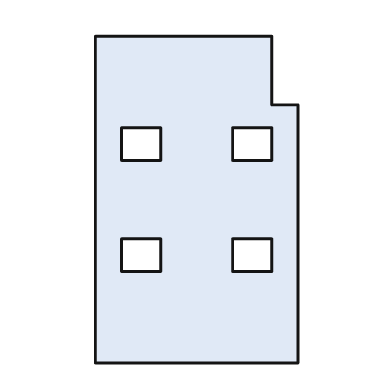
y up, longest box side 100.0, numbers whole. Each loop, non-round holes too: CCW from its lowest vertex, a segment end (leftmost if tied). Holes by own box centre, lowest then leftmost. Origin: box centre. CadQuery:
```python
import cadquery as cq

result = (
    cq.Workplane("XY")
    .moveTo(-31.0, -50.0)
    .lineTo(31.0, -50.0)
    .lineTo(31.0, 29.0)
    .lineTo(23.0, 29.0)
    .lineTo(23.0, 50.0)
    .lineTo(-31.0, 50.0)
    .close()
    .moveTo(-23.0, -22.0)
    .lineTo(-11.0, -22.0)
    .lineTo(-11.0, -12.0)
    .lineTo(-23.0, -12.0)
    .close()
    .moveTo(11.0, -22.0)
    .lineTo(23.0, -22.0)
    .lineTo(23.0, -12.0)
    .lineTo(11.0, -12.0)
    .close()
    .moveTo(-23.0, 12.0)
    .lineTo(-11.0, 12.0)
    .lineTo(-11.0, 22.0)
    .lineTo(-23.0, 22.0)
    .close()
    .moveTo(11.0, 12.0)
    .lineTo(23.0, 12.0)
    .lineTo(23.0, 22.0)
    .lineTo(11.0, 22.0)
    .close()
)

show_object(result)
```